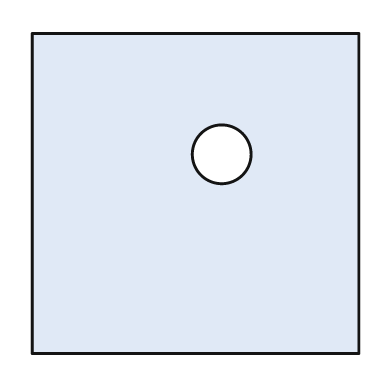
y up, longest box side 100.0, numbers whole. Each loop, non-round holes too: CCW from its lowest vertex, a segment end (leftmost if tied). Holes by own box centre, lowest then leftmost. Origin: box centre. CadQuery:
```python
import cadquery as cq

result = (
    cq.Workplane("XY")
    .moveTo(-50.0, -49.0)
    .lineTo(50.0, -49.0)
    .lineTo(50.0, 49.0)
    .lineTo(-50.0, 49.0)
    .close()
    .moveTo(8.0, 12.0)
    .circle(9.0)
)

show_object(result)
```